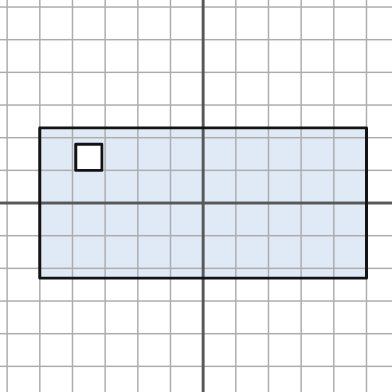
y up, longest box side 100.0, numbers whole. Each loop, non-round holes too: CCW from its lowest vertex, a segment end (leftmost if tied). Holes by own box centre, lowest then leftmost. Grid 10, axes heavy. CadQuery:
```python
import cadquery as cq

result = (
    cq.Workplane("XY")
    .moveTo(-50.0, -23.0)
    .lineTo(50.0, -23.0)
    .lineTo(50.0, 23.0)
    .lineTo(-50.0, 23.0)
    .close()
    .moveTo(-39.0, 10.0)
    .lineTo(-31.0, 10.0)
    .lineTo(-31.0, 18.0)
    .lineTo(-39.0, 18.0)
    .close()
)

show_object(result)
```